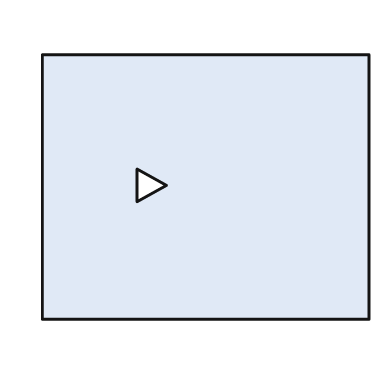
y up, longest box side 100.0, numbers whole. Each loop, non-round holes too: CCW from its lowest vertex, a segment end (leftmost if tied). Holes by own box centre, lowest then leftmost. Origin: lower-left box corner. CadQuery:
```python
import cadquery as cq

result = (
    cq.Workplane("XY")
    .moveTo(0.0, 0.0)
    .lineTo(100.0, 0.0)
    .lineTo(100.0, 81.0)
    .lineTo(0.0, 81.0)
    .close()
    .moveTo(29.0, 36.0)
    .lineTo(38.0, 41.0)
    .lineTo(29.0, 46.0)
    .close()
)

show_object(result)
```